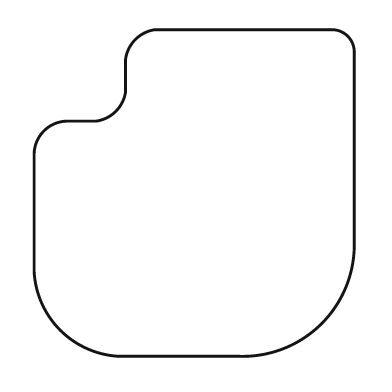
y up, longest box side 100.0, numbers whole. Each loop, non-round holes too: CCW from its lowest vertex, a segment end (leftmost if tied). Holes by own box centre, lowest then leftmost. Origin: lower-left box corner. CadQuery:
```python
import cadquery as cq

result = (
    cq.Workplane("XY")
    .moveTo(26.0, 0.0)
    .lineTo(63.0, 0.0)
    .threePointArc((88.0, 10.0), (98.0, 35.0))
    .lineTo(98.0, 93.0)
    .threePointArc((96.0, 98.0), (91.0, 100.0))
    .lineTo(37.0, 100.0)
    .threePointArc((31.0, 97.0), (28.0, 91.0))
    .lineTo(28.0, 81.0)
    .threePointArc((25.0, 75.0), (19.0, 72.0))
    .lineTo(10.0, 72.0)
    .threePointArc((3.0, 69.0), (0.0, 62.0))
    .lineTo(0.0, 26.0)
    .threePointArc((8.0, 8.0), (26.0, 0.0))
    .close()
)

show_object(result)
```